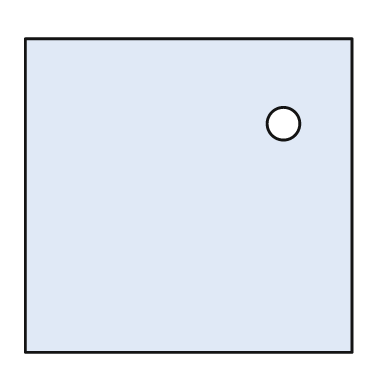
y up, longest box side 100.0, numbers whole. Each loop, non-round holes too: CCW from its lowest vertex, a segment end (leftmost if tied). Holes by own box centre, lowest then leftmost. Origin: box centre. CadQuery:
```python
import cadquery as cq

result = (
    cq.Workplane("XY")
    .moveTo(-50.0, -48.0)
    .lineTo(50.0, -48.0)
    .lineTo(50.0, 48.0)
    .lineTo(-50.0, 48.0)
    .close()
    .moveTo(29.0, 22.0)
    .circle(5.0)
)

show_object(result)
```